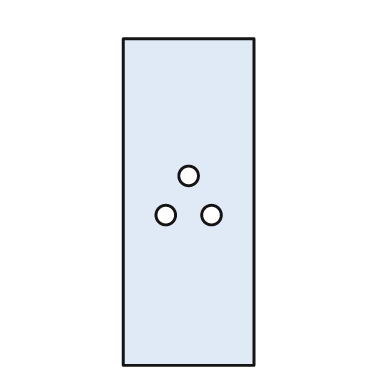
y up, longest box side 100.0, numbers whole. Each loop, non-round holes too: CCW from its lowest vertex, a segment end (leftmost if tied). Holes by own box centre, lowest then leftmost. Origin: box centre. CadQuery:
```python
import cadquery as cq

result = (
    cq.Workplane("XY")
    .moveTo(-20.0, -50.0)
    .lineTo(20.0, -50.0)
    .lineTo(20.0, 50.0)
    .lineTo(-20.0, 50.0)
    .close()
    .moveTo(-7.0, -4.0)
    .circle(3.0)
    .moveTo(7.0, -4.0)
    .circle(3.0)
    .moveTo(0.0, 8.0)
    .circle(3.0)
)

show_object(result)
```